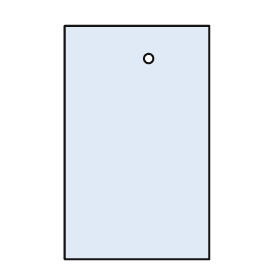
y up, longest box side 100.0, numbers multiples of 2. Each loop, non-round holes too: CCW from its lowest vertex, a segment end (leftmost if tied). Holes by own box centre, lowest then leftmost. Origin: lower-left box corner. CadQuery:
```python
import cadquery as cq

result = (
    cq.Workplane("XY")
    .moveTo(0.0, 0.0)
    .lineTo(62.0, 0.0)
    .lineTo(62.0, 100.0)
    .lineTo(0.0, 100.0)
    .close()
    .moveTo(36.0, 86.0)
    .circle(2.0)
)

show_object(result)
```